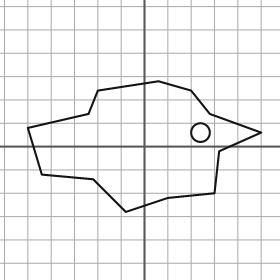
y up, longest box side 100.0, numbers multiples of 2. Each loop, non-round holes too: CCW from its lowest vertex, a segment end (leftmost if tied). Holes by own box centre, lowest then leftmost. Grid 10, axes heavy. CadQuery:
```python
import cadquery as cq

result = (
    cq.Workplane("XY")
    .moveTo(-8.0, -28.0)
    .lineTo(10.0, -22.0)
    .lineTo(30.0, -20.0)
    .lineTo(32.0, -2.0)
    .lineTo(50.0, 6.0)
    .lineTo(28.0, 14.0)
    .lineTo(20.0, 24.0)
    .lineTo(6.0, 28.0)
    .lineTo(-20.0, 24.0)
    .lineTo(-24.0, 14.0)
    .lineTo(-50.0, 8.0)
    .lineTo(-44.0, -12.0)
    .lineTo(-22.0, -14.0)
    .close()
    .moveTo(24.0, 6.0)
    .circle(4.0)
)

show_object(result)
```